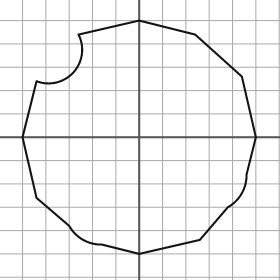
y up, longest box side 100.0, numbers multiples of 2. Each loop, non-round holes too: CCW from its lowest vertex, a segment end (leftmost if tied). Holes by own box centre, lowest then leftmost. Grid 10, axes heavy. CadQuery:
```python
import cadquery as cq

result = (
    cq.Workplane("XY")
    .moveTo(0.0, -50.0)
    .lineTo(26.0, -44.0)
    .lineTo(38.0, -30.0)
    .threePointArc((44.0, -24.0), (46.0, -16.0))
    .lineTo(50.0, 0.0)
    .lineTo(44.0, 26.0)
    .lineTo(24.0, 44.0)
    .lineTo(0.0, 50.0)
    .lineTo(-26.0, 44.0)
    .threePointArc((-28.0, 28.0), (-44.0, 24.0))
    .lineTo(-50.0, 0.0)
    .lineTo(-44.0, -26.0)
    .lineTo(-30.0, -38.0)
    .threePointArc((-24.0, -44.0), (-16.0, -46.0))
    .close()
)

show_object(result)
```